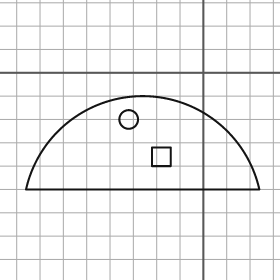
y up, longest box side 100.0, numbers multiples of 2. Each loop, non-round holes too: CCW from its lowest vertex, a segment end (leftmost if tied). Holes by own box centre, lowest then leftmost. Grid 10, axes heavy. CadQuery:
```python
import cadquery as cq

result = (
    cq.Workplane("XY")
    .moveTo(-76.0, -50.0)
    .lineTo(24.0, -50.0)
    .threePointArc((-26.0, -10.0), (-76.0, -50.0))
    .close()
    .moveTo(-22.0, -40.0)
    .lineTo(-14.0, -40.0)
    .lineTo(-14.0, -32.0)
    .lineTo(-22.0, -32.0)
    .close()
    .moveTo(-32.0, -20.0)
    .circle(4.0)
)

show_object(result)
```